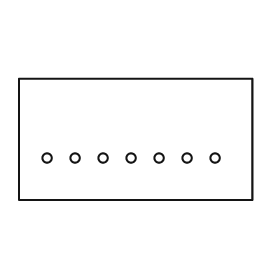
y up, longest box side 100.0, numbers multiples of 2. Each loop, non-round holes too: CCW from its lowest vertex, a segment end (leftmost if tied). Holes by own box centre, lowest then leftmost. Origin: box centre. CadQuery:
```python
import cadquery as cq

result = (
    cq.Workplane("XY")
    .moveTo(-50.0, -26.0)
    .lineTo(50.0, -26.0)
    .lineTo(50.0, 26.0)
    .lineTo(-50.0, 26.0)
    .close()
    .moveTo(-38.0, -8.0)
    .circle(2.0)
    .moveTo(-26.0, -8.0)
    .circle(2.0)
    .moveTo(-14.0, -8.0)
    .circle(2.0)
    .moveTo(-2.0, -8.0)
    .circle(2.0)
    .moveTo(10.0, -8.0)
    .circle(2.0)
    .moveTo(22.0, -8.0)
    .circle(2.0)
    .moveTo(34.0, -8.0)
    .circle(2.0)
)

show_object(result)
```